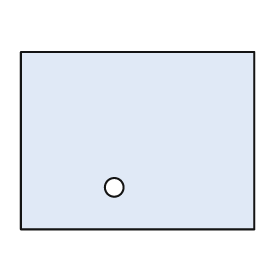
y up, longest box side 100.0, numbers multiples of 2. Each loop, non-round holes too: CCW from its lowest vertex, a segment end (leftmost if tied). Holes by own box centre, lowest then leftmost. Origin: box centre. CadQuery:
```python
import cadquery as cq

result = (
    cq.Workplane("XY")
    .moveTo(-50.0, -38.0)
    .lineTo(50.0, -38.0)
    .lineTo(50.0, 38.0)
    .lineTo(-50.0, 38.0)
    .close()
    .moveTo(-10.0, -20.0)
    .circle(4.0)
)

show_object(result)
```